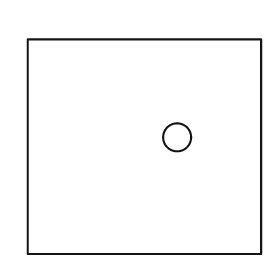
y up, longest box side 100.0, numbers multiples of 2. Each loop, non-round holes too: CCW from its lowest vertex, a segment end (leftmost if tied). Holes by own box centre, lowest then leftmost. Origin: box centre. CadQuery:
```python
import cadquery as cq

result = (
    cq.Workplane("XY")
    .moveTo(-50.0, -46.0)
    .lineTo(50.0, -46.0)
    .lineTo(50.0, 46.0)
    .lineTo(-50.0, 46.0)
    .close()
    .moveTo(14.0, 4.0)
    .circle(6.0)
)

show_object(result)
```